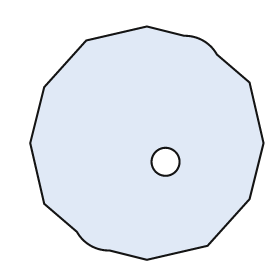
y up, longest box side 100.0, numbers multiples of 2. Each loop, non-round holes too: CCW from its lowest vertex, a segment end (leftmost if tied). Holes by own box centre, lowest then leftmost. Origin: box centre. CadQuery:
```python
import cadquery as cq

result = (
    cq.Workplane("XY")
    .moveTo(0.0, -50.0)
    .lineTo(26.0, -44.0)
    .lineTo(44.0, -24.0)
    .lineTo(50.0, 0.0)
    .lineTo(44.0, 26.0)
    .lineTo(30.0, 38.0)
    .threePointArc((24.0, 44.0), (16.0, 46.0))
    .lineTo(0.0, 50.0)
    .lineTo(-26.0, 44.0)
    .lineTo(-44.0, 24.0)
    .lineTo(-50.0, 0.0)
    .lineTo(-44.0, -26.0)
    .lineTo(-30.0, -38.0)
    .threePointArc((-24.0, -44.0), (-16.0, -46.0))
    .close()
    .moveTo(8.0, -8.0)
    .circle(6.0)
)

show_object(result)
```